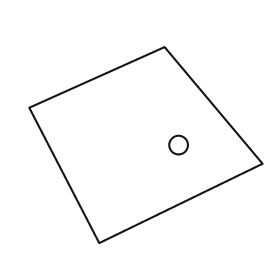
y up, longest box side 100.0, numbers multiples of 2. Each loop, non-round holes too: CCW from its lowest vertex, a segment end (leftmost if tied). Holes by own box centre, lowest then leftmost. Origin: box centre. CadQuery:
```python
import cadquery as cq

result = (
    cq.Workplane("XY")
    .moveTo(-20.0, -42.0)
    .lineTo(50.0, -8.0)
    .lineTo(8.0, 42.0)
    .lineTo(-50.0, 16.0)
    .close()
    .moveTo(14.0, 0.0)
    .circle(4.0)
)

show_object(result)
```